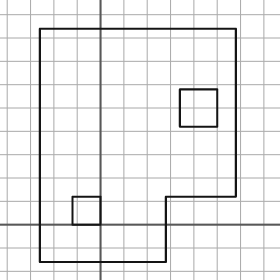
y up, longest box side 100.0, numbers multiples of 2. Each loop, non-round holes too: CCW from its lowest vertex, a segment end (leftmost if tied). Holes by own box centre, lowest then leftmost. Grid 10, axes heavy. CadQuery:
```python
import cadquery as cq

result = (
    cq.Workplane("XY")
    .moveTo(-26.0, -16.0)
    .lineTo(28.0, -16.0)
    .lineTo(28.0, 12.0)
    .lineTo(58.0, 12.0)
    .lineTo(58.0, 84.0)
    .lineTo(-26.0, 84.0)
    .close()
    .moveTo(-12.0, 0.0)
    .lineTo(0.0, 0.0)
    .lineTo(0.0, 12.0)
    .lineTo(-12.0, 12.0)
    .close()
    .moveTo(34.0, 42.0)
    .lineTo(50.0, 42.0)
    .lineTo(50.0, 58.0)
    .lineTo(34.0, 58.0)
    .close()
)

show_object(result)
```